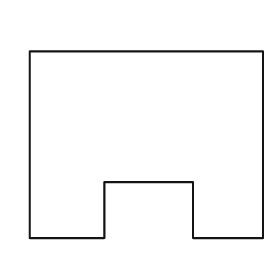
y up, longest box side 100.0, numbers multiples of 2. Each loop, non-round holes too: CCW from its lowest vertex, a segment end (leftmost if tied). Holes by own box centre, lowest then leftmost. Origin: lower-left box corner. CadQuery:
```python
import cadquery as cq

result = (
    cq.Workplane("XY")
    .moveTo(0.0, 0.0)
    .lineTo(32.0, 0.0)
    .lineTo(32.0, 24.0)
    .lineTo(70.0, 24.0)
    .lineTo(70.0, 0.0)
    .lineTo(100.0, 0.0)
    .lineTo(100.0, 80.0)
    .lineTo(0.0, 80.0)
    .close()
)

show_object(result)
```